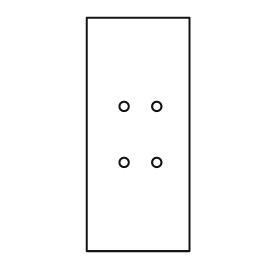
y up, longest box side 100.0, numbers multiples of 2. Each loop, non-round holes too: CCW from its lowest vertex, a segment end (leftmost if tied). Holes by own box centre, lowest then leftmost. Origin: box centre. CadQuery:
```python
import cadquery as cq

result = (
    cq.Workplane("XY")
    .moveTo(-22.0, -50.0)
    .lineTo(22.0, -50.0)
    .lineTo(22.0, 50.0)
    .lineTo(-22.0, 50.0)
    .close()
    .moveTo(-6.0, -12.0)
    .circle(2.0)
    .moveTo(8.0, -12.0)
    .circle(2.0)
    .moveTo(-6.0, 12.0)
    .circle(2.0)
    .moveTo(8.0, 12.0)
    .circle(2.0)
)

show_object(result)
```